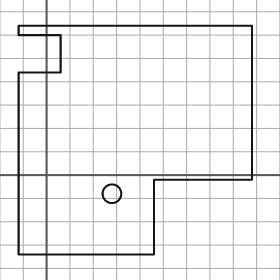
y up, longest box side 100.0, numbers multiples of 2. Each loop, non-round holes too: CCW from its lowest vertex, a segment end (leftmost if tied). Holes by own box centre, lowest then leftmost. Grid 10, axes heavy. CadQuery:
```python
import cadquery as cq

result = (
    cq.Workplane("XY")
    .moveTo(-12.0, -34.0)
    .lineTo(46.0, -34.0)
    .lineTo(46.0, -2.0)
    .lineTo(88.0, -2.0)
    .lineTo(88.0, 64.0)
    .lineTo(-12.0, 64.0)
    .lineTo(-12.0, 60.0)
    .lineTo(6.0, 60.0)
    .lineTo(6.0, 44.0)
    .lineTo(-12.0, 44.0)
    .close()
    .moveTo(28.0, -8.0)
    .circle(4.0)
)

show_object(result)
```